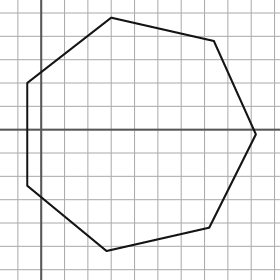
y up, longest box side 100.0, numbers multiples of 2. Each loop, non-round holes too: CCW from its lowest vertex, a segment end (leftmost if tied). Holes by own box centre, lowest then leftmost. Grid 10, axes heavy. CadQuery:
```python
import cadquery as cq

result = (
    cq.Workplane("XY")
    .moveTo(28.0, -52.0)
    .lineTo(72.0, -42.0)
    .lineTo(92.0, -2.0)
    .lineTo(74.0, 38.0)
    .lineTo(30.0, 48.0)
    .lineTo(-6.0, 20.0)
    .lineTo(-6.0, -24.0)
    .close()
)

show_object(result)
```